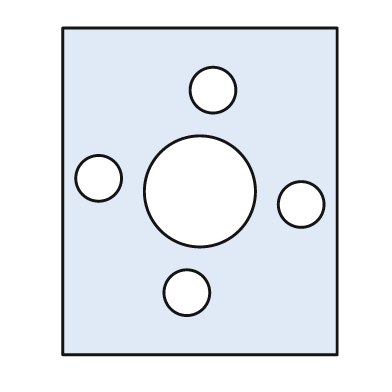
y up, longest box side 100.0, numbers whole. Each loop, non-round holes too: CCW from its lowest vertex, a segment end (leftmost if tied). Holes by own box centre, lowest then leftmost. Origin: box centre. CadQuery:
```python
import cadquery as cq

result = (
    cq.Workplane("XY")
    .moveTo(-42.0, -50.0)
    .lineTo(42.0, -50.0)
    .lineTo(42.0, 50.0)
    .lineTo(-42.0, 50.0)
    .close()
    .moveTo(-4.0, -31.0)
    .circle(7.0)
    .moveTo(31.0, -4.0)
    .circle(7.0)
    .moveTo(0.0, 0.0)
    .circle(17.0)
    .moveTo(-31.0, 4.0)
    .circle(7.0)
    .moveTo(4.0, 31.0)
    .circle(7.0)
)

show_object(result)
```